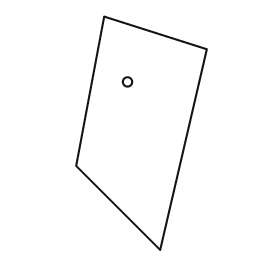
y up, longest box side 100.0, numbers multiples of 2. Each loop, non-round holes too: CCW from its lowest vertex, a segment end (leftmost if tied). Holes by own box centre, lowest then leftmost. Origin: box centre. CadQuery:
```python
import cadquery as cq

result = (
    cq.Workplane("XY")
    .moveTo(8.0, -50.0)
    .lineTo(28.0, 36.0)
    .lineTo(-16.0, 50.0)
    .lineTo(-28.0, -14.0)
    .close()
    .moveTo(-6.0, 22.0)
    .circle(2.0)
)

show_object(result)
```